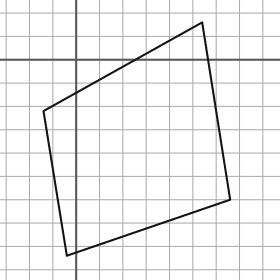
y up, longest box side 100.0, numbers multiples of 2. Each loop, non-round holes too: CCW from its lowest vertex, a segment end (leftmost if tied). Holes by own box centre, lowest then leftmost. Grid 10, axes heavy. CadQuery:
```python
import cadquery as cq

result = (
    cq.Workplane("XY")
    .moveTo(-4.0, -84.0)
    .lineTo(66.0, -60.0)
    .lineTo(54.0, 16.0)
    .lineTo(-14.0, -22.0)
    .close()
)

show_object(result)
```